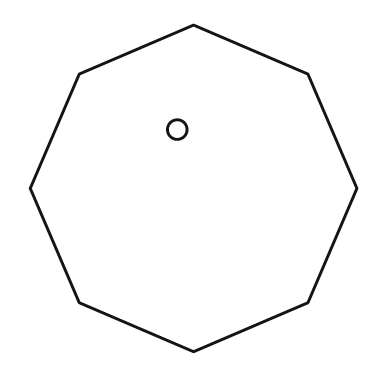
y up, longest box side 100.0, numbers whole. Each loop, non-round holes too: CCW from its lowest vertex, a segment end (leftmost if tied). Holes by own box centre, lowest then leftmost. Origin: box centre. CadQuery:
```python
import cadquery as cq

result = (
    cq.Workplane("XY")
    .moveTo(0.0, -50.0)
    .lineTo(35.0, -35.0)
    .lineTo(50.0, 0.0)
    .lineTo(35.0, 35.0)
    .lineTo(0.0, 50.0)
    .lineTo(-35.0, 35.0)
    .lineTo(-50.0, 0.0)
    .lineTo(-35.0, -35.0)
    .close()
    .moveTo(-5.0, 18.0)
    .circle(3.0)
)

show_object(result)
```